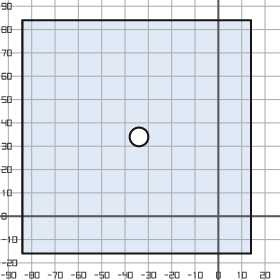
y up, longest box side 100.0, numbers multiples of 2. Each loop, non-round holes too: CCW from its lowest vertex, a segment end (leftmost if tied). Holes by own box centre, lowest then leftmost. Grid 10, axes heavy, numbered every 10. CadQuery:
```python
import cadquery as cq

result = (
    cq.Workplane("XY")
    .moveTo(-84.0, -16.0)
    .lineTo(14.0, -16.0)
    .lineTo(14.0, 84.0)
    .lineTo(-84.0, 84.0)
    .close()
    .moveTo(-34.0, 34.0)
    .circle(4.0)
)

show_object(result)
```